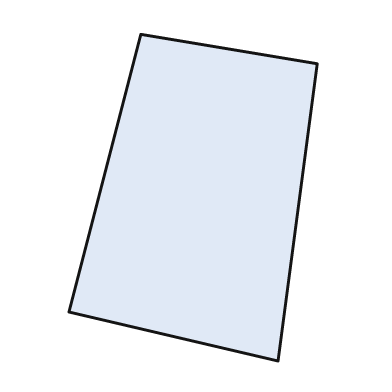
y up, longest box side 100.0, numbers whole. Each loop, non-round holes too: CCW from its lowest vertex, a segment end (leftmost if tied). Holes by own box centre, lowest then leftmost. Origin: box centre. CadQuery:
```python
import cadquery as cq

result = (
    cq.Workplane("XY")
    .moveTo(26.0, -50.0)
    .lineTo(38.0, 41.0)
    .lineTo(-16.0, 50.0)
    .lineTo(-38.0, -35.0)
    .close()
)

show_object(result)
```